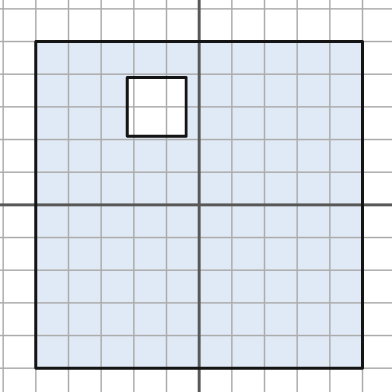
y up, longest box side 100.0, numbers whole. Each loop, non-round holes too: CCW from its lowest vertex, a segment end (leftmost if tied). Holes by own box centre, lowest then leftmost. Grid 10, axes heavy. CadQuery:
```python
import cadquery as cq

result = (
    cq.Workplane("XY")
    .moveTo(-50.0, -50.0)
    .lineTo(50.0, -50.0)
    .lineTo(50.0, 50.0)
    .lineTo(-50.0, 50.0)
    .close()
    .moveTo(-22.0, 21.0)
    .lineTo(-4.0, 21.0)
    .lineTo(-4.0, 39.0)
    .lineTo(-22.0, 39.0)
    .close()
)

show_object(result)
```